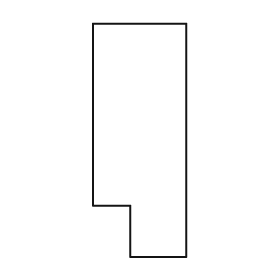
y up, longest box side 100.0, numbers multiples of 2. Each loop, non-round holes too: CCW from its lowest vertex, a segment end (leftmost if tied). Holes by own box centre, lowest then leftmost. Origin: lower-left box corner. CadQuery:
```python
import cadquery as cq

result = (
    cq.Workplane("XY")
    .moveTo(16.0, 0.0)
    .lineTo(40.0, 0.0)
    .lineTo(40.0, 100.0)
    .lineTo(0.0, 100.0)
    .lineTo(0.0, 22.0)
    .lineTo(16.0, 22.0)
    .close()
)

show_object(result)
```